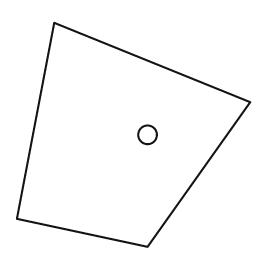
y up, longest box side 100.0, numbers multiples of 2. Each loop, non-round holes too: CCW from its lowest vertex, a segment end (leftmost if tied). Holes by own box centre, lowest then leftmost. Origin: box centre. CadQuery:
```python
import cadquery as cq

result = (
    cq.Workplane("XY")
    .moveTo(6.0, -48.0)
    .lineTo(50.0, 14.0)
    .lineTo(-34.0, 48.0)
    .lineTo(-50.0, -36.0)
    .close()
    .moveTo(6.0, 0.0)
    .circle(4.0)
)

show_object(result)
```